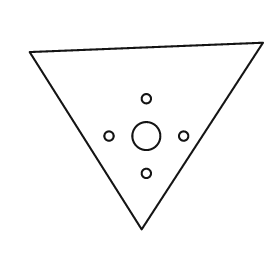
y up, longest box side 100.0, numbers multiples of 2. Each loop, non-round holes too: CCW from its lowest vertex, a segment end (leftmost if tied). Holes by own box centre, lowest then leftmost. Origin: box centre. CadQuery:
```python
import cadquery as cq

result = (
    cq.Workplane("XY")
    .moveTo(-2.0, -40.0)
    .lineTo(50.0, 40.0)
    .lineTo(-50.0, 36.0)
    .close()
    .moveTo(0.0, -16.0)
    .circle(2.0)
    .moveTo(-16.0, 0.0)
    .circle(2.0)
    .moveTo(0.0, 0.0)
    .circle(6.0)
    .moveTo(16.0, 0.0)
    .circle(2.0)
    .moveTo(0.0, 16.0)
    .circle(2.0)
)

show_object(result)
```